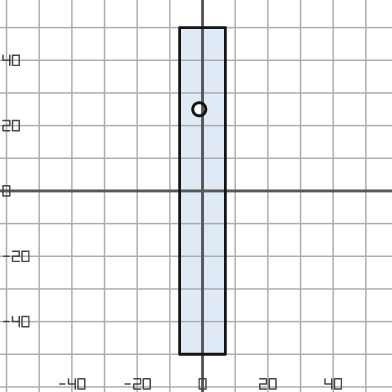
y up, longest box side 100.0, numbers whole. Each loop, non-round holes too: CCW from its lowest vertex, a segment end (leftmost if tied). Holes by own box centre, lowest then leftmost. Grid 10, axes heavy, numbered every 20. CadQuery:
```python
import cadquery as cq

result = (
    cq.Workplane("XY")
    .moveTo(-7.0, -50.0)
    .lineTo(7.0, -50.0)
    .lineTo(7.0, 50.0)
    .lineTo(-7.0, 50.0)
    .close()
    .moveTo(-1.0, 25.0)
    .circle(2.0)
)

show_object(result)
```